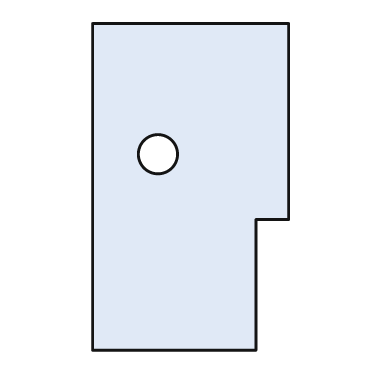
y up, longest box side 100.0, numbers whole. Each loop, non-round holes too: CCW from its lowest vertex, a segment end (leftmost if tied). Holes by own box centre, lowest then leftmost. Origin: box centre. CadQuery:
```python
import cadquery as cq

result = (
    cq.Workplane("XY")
    .moveTo(-30.0, -50.0)
    .lineTo(20.0, -50.0)
    .lineTo(20.0, -10.0)
    .lineTo(30.0, -10.0)
    .lineTo(30.0, 50.0)
    .lineTo(-30.0, 50.0)
    .close()
    .moveTo(-10.0, 10.0)
    .circle(6.0)
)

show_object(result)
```